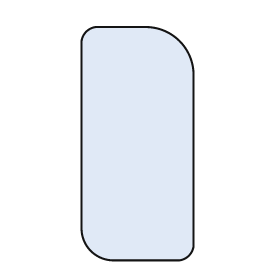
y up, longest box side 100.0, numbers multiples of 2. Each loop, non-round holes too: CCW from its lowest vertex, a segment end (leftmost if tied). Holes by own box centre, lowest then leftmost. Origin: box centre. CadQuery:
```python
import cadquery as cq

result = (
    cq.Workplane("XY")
    .moveTo(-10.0, -50.0)
    .lineTo(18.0, -50.0)
    .threePointArc((22.0, -48.0), (24.0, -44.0))
    .lineTo(24.0, 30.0)
    .threePointArc((18.0, 44.0), (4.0, 50.0))
    .lineTo(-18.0, 50.0)
    .threePointArc((-22.0, 48.0), (-24.0, 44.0))
    .lineTo(-24.0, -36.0)
    .threePointArc((-20.0, -46.0), (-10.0, -50.0))
    .close()
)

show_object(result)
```